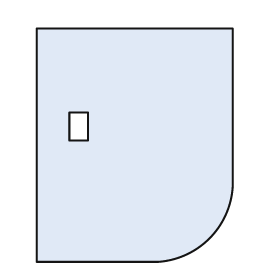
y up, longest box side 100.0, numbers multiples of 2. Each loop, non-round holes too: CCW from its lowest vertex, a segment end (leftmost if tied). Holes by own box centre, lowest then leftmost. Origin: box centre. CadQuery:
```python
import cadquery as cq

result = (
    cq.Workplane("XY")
    .moveTo(-42.0, -50.0)
    .lineTo(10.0, -50.0)
    .threePointArc((32.0, -40.0), (42.0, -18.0))
    .lineTo(42.0, 50.0)
    .lineTo(-42.0, 50.0)
    .close()
    .moveTo(-28.0, 2.0)
    .lineTo(-20.0, 2.0)
    .lineTo(-20.0, 14.0)
    .lineTo(-28.0, 14.0)
    .close()
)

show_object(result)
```